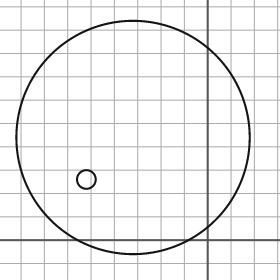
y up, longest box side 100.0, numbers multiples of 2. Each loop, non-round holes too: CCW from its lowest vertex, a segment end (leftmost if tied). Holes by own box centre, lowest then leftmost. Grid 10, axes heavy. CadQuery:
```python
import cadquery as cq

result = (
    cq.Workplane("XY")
    .moveTo(-32.0, 44.0)
    .circle(50.0)
    .moveTo(-52.0, 26.0)
    .circle(4.0)
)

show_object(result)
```